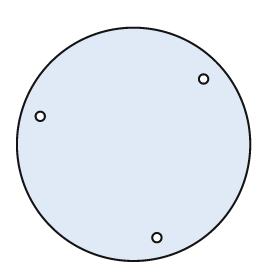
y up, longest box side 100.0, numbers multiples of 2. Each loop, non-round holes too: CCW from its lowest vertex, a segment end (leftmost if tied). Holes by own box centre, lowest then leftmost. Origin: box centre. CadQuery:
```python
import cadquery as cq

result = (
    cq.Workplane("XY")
    .moveTo(0.0, 0.0)
    .circle(50.0)
    .moveTo(10.0, -40.0)
    .circle(2.0)
    .moveTo(-40.0, 12.0)
    .circle(2.0)
    .moveTo(30.0, 28.0)
    .circle(2.0)
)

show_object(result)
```